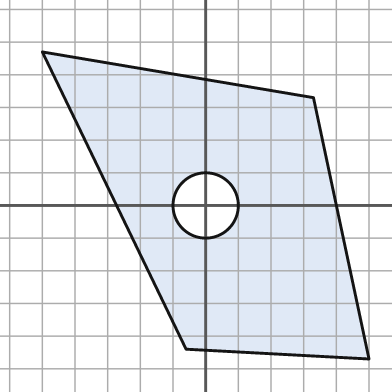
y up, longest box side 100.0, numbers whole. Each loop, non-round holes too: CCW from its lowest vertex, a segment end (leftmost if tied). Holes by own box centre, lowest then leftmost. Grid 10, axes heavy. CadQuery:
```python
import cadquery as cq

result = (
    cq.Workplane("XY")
    .moveTo(50.0, -47.0)
    .lineTo(33.0, 33.0)
    .lineTo(-50.0, 47.0)
    .lineTo(-6.0, -44.0)
    .close()
    .moveTo(0.0, 0.0)
    .circle(10.0)
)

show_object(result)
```